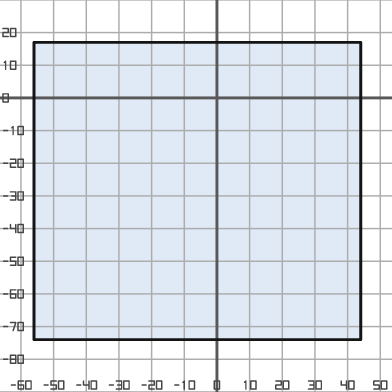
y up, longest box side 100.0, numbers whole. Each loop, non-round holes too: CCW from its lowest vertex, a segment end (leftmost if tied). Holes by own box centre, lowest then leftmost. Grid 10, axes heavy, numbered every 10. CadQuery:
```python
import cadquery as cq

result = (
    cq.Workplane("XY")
    .moveTo(-56.0, -74.0)
    .lineTo(44.0, -74.0)
    .lineTo(44.0, 17.0)
    .lineTo(-56.0, 17.0)
    .close()
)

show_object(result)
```